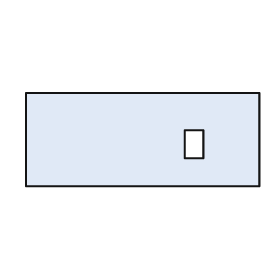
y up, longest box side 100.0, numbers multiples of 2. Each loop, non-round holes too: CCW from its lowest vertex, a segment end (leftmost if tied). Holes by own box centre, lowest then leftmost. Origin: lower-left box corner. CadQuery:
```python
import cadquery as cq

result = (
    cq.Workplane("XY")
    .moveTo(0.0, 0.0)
    .lineTo(100.0, 0.0)
    .lineTo(100.0, 40.0)
    .lineTo(0.0, 40.0)
    .close()
    .moveTo(68.0, 12.0)
    .lineTo(76.0, 12.0)
    .lineTo(76.0, 24.0)
    .lineTo(68.0, 24.0)
    .close()
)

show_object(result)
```